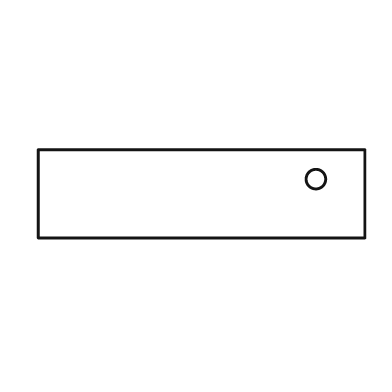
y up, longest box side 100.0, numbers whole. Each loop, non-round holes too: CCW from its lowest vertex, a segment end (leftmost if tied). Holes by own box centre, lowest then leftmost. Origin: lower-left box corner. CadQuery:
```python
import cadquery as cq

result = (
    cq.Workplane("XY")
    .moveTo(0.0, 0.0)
    .lineTo(100.0, 0.0)
    .lineTo(100.0, 27.0)
    .lineTo(0.0, 27.0)
    .close()
    .moveTo(85.0, 18.0)
    .circle(3.0)
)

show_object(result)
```